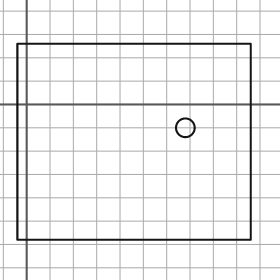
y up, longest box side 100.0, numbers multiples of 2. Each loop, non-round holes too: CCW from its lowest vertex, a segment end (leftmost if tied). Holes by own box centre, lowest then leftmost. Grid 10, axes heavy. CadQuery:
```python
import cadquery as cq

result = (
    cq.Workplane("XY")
    .moveTo(-4.0, -58.0)
    .lineTo(96.0, -58.0)
    .lineTo(96.0, 26.0)
    .lineTo(-4.0, 26.0)
    .close()
    .moveTo(68.0, -10.0)
    .circle(4.0)
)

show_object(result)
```